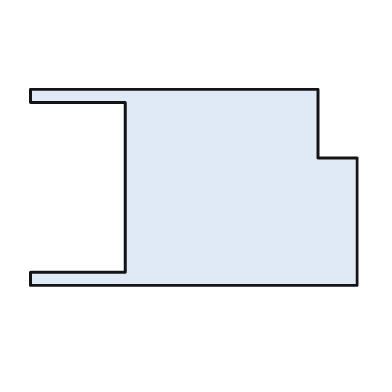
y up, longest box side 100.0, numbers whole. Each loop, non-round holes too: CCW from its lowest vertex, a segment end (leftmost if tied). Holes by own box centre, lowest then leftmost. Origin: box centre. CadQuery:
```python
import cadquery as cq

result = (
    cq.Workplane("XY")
    .moveTo(-50.0, -30.0)
    .lineTo(50.0, -30.0)
    .lineTo(50.0, 9.0)
    .lineTo(38.0, 9.0)
    .lineTo(38.0, 30.0)
    .lineTo(-50.0, 30.0)
    .lineTo(-50.0, 26.0)
    .lineTo(-21.0, 26.0)
    .lineTo(-21.0, -26.0)
    .lineTo(-50.0, -26.0)
    .close()
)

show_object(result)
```